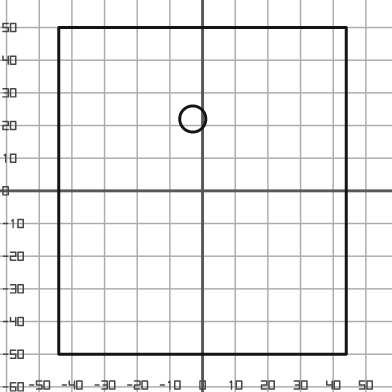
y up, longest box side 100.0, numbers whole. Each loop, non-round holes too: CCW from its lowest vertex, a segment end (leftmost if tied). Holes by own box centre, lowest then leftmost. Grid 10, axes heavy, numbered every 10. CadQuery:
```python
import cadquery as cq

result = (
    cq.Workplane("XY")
    .moveTo(-44.0, -50.0)
    .lineTo(44.0, -50.0)
    .lineTo(44.0, 50.0)
    .lineTo(-44.0, 50.0)
    .close()
    .moveTo(-3.0, 22.0)
    .circle(4.0)
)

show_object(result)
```